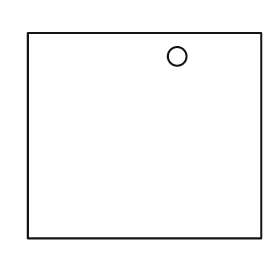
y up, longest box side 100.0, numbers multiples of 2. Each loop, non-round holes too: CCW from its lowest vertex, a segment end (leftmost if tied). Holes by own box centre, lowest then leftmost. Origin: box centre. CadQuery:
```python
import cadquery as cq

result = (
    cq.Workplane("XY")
    .moveTo(-50.0, -44.0)
    .lineTo(50.0, -44.0)
    .lineTo(50.0, 44.0)
    .lineTo(-50.0, 44.0)
    .close()
    .moveTo(14.0, 34.0)
    .circle(4.0)
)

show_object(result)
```